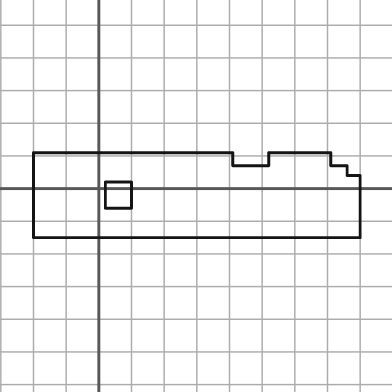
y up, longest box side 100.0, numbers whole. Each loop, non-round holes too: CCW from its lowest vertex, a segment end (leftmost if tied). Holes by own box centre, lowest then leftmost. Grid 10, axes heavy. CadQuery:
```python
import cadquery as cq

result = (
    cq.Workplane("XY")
    .moveTo(-20.0, -15.0)
    .lineTo(80.0, -15.0)
    .lineTo(80.0, 4.0)
    .lineTo(76.0, 4.0)
    .lineTo(76.0, 7.0)
    .lineTo(71.0, 7.0)
    .lineTo(71.0, 11.0)
    .lineTo(52.0, 11.0)
    .lineTo(52.0, 7.0)
    .lineTo(41.0, 7.0)
    .lineTo(41.0, 11.0)
    .lineTo(-20.0, 11.0)
    .close()
    .moveTo(2.0, -6.0)
    .lineTo(10.0, -6.0)
    .lineTo(10.0, 2.0)
    .lineTo(2.0, 2.0)
    .close()
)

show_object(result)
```